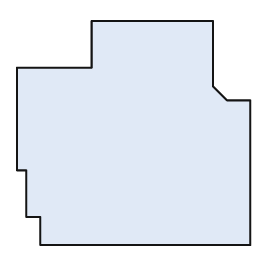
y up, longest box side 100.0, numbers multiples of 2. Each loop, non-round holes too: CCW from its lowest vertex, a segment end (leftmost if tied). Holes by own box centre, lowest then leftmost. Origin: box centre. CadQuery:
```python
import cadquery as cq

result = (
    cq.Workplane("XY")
    .moveTo(-40.0, -48.0)
    .lineTo(50.0, -48.0)
    .lineTo(50.0, 14.0)
    .lineTo(40.0, 14.0)
    .lineTo(34.0, 20.0)
    .lineTo(34.0, 48.0)
    .lineTo(-18.0, 48.0)
    .lineTo(-18.0, 28.0)
    .lineTo(-50.0, 28.0)
    .lineTo(-50.0, -16.0)
    .lineTo(-46.0, -16.0)
    .lineTo(-46.0, -36.0)
    .lineTo(-40.0, -36.0)
    .close()
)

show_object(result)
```